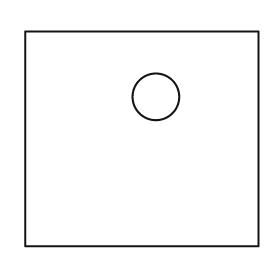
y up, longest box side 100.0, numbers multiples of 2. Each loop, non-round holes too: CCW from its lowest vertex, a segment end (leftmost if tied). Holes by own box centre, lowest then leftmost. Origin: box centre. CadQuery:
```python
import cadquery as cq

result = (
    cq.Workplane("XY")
    .moveTo(-50.0, -46.0)
    .lineTo(50.0, -46.0)
    .lineTo(50.0, 46.0)
    .lineTo(-50.0, 46.0)
    .close()
    .moveTo(6.0, 18.0)
    .circle(10.0)
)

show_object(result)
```